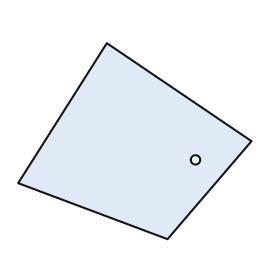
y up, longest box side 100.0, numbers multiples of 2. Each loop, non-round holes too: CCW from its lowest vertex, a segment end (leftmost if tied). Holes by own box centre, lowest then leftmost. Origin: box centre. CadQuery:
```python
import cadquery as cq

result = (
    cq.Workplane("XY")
    .moveTo(14.0, -42.0)
    .lineTo(50.0, 0.0)
    .lineTo(-12.0, 42.0)
    .lineTo(-50.0, -18.0)
    .close()
    .moveTo(26.0, -8.0)
    .circle(2.0)
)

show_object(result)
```